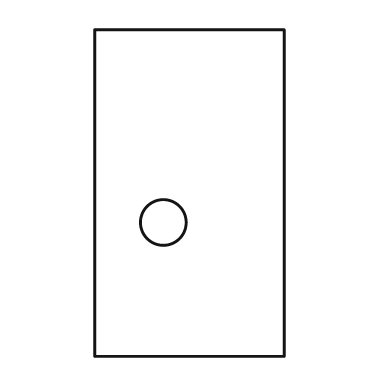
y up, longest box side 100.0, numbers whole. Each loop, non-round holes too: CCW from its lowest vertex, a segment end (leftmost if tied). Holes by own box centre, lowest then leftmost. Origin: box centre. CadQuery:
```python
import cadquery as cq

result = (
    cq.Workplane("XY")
    .moveTo(-29.0, -50.0)
    .lineTo(29.0, -50.0)
    .lineTo(29.0, 50.0)
    .lineTo(-29.0, 50.0)
    .close()
    .moveTo(-8.0, -9.0)
    .circle(7.0)
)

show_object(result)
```